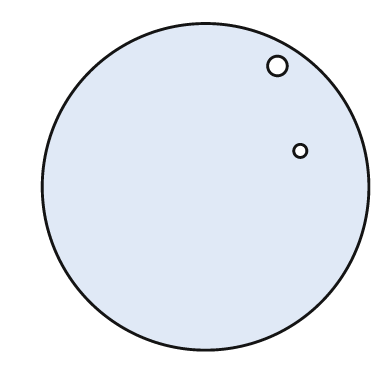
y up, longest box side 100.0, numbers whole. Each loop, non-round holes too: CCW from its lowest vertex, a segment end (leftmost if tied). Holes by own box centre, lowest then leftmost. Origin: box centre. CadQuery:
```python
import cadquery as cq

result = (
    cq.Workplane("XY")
    .moveTo(0.0, 0.0)
    .circle(50.0)
    .moveTo(29.0, 11.0)
    .circle(2.0)
    .moveTo(22.0, 37.0)
    .circle(3.0)
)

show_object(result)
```